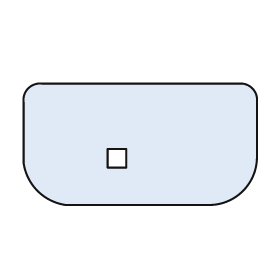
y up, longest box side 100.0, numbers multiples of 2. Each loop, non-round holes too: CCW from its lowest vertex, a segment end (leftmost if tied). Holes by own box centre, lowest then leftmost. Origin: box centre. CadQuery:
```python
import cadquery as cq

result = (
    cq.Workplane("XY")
    .moveTo(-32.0, -26.0)
    .lineTo(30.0, -26.0)
    .threePointArc((44.0, -20.0), (50.0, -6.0))
    .lineTo(50.0, 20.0)
    .threePointArc((48.0, 24.0), (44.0, 26.0))
    .lineTo(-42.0, 26.0)
    .threePointArc((-48.0, 24.0), (-50.0, 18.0))
    .lineTo(-50.0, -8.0)
    .threePointArc((-44.0, -20.0), (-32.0, -26.0))
    .close()
    .moveTo(-14.0, -10.0)
    .lineTo(-6.0, -10.0)
    .lineTo(-6.0, -2.0)
    .lineTo(-14.0, -2.0)
    .close()
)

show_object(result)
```